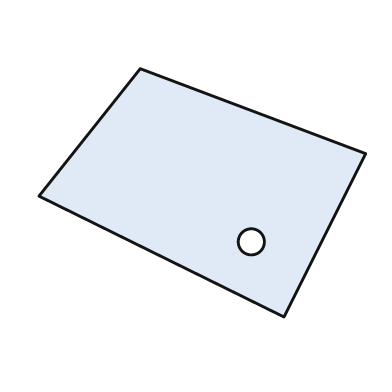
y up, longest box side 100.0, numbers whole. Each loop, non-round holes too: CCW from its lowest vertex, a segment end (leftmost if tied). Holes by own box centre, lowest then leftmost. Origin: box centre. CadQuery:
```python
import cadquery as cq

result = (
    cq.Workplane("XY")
    .moveTo(25.0, -38.0)
    .lineTo(50.0, 12.0)
    .lineTo(-19.0, 38.0)
    .lineTo(-50.0, -1.0)
    .close()
    .moveTo(15.0, -15.0)
    .circle(4.0)
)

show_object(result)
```